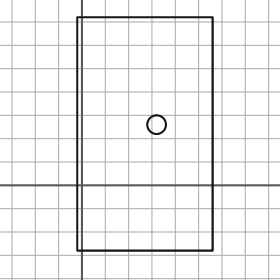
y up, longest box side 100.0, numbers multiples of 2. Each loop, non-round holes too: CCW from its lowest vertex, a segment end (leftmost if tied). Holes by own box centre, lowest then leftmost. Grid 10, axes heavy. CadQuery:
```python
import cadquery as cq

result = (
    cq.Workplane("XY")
    .moveTo(-2.0, -28.0)
    .lineTo(56.0, -28.0)
    .lineTo(56.0, 72.0)
    .lineTo(-2.0, 72.0)
    .close()
    .moveTo(32.0, 26.0)
    .circle(4.0)
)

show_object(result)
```